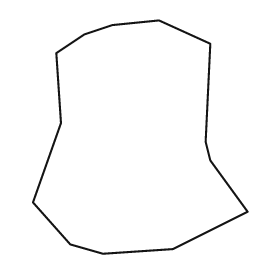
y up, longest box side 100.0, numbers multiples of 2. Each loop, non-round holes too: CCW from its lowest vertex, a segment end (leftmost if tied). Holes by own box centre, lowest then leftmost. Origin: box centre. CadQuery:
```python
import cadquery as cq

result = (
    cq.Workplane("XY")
    .moveTo(-16.0, -50.0)
    .lineTo(14.0, -48.0)
    .lineTo(46.0, -32.0)
    .lineTo(30.0, -10.0)
    .lineTo(28.0, -2.0)
    .lineTo(30.0, 40.0)
    .lineTo(8.0, 50.0)
    .lineTo(-12.0, 48.0)
    .lineTo(-24.0, 44.0)
    .lineTo(-36.0, 36.0)
    .lineTo(-34.0, 6.0)
    .lineTo(-46.0, -28.0)
    .lineTo(-30.0, -46.0)
    .close()
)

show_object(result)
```